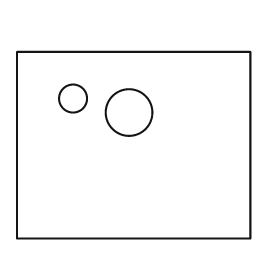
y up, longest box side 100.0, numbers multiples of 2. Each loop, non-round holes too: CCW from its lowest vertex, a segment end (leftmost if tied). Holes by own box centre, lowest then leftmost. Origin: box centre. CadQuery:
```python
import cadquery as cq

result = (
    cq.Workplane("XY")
    .moveTo(-50.0, -40.0)
    .lineTo(50.0, -40.0)
    .lineTo(50.0, 40.0)
    .lineTo(-50.0, 40.0)
    .close()
    .moveTo(-2.0, 14.0)
    .circle(10.0)
    .moveTo(-26.0, 20.0)
    .circle(6.0)
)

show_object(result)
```